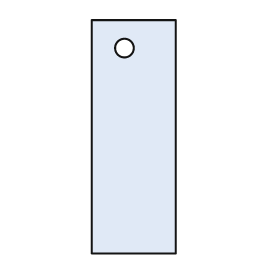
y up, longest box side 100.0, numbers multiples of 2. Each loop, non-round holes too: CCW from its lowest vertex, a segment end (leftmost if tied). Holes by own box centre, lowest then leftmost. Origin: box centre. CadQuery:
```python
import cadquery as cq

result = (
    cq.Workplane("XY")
    .moveTo(-18.0, -50.0)
    .lineTo(18.0, -50.0)
    .lineTo(18.0, 50.0)
    .lineTo(-18.0, 50.0)
    .close()
    .moveTo(-4.0, 38.0)
    .circle(4.0)
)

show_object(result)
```